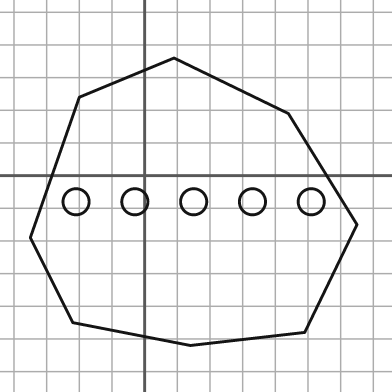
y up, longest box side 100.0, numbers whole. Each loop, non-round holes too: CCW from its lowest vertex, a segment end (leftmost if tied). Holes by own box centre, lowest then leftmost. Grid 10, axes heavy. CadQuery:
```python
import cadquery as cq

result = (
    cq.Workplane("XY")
    .moveTo(14.0, -52.0)
    .lineTo(49.0, -48.0)
    .lineTo(65.0, -15.0)
    .lineTo(44.0, 19.0)
    .lineTo(9.0, 36.0)
    .lineTo(-20.0, 24.0)
    .lineTo(-35.0, -19.0)
    .lineTo(-22.0, -45.0)
    .close()
    .moveTo(-21.0, -8.0)
    .circle(4.0)
    .moveTo(-3.0, -8.0)
    .circle(4.0)
    .moveTo(15.0, -8.0)
    .circle(4.0)
    .moveTo(33.0, -8.0)
    .circle(4.0)
    .moveTo(51.0, -8.0)
    .circle(4.0)
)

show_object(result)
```